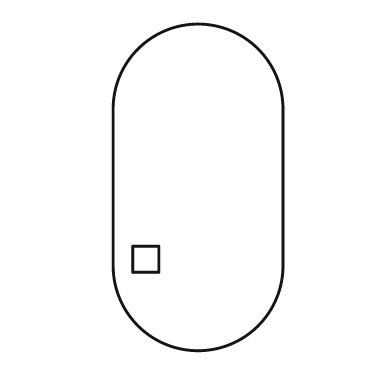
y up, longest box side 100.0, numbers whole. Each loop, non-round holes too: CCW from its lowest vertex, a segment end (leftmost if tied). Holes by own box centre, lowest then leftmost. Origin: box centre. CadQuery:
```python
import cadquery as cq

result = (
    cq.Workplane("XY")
    .moveTo(-26.0, -24.0)
    .threePointArc((0.0, -50.0), (26.0, -24.0))
    .lineTo(26.0, 24.0)
    .threePointArc((0.0, 50.0), (-26.0, 24.0))
    .close()
    .moveTo(-20.0, -26.0)
    .lineTo(-12.0, -26.0)
    .lineTo(-12.0, -18.0)
    .lineTo(-20.0, -18.0)
    .close()
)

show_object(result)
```